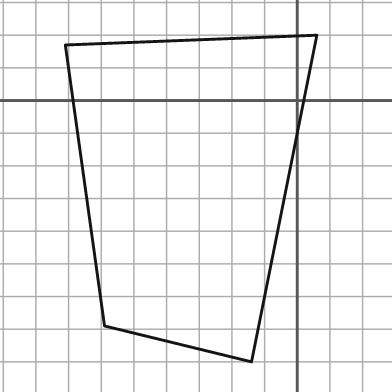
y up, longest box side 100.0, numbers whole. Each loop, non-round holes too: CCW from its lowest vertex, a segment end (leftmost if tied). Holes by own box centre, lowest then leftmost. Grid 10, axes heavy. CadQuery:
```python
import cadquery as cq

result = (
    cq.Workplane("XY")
    .moveTo(-14.0, -80.0)
    .lineTo(6.0, 20.0)
    .lineTo(-71.0, 17.0)
    .lineTo(-59.0, -69.0)
    .close()
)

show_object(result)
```